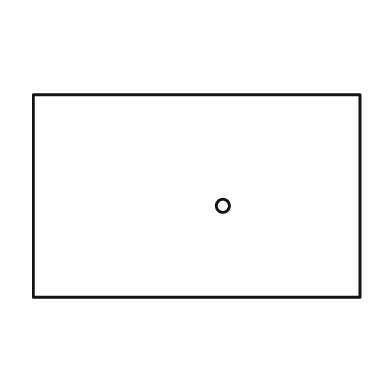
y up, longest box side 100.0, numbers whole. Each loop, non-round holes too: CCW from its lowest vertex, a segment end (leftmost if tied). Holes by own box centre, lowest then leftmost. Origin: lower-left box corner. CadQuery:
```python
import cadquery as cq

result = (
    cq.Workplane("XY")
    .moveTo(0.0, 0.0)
    .lineTo(100.0, 0.0)
    .lineTo(100.0, 62.0)
    .lineTo(0.0, 62.0)
    .close()
    .moveTo(58.0, 28.0)
    .circle(2.0)
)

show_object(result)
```